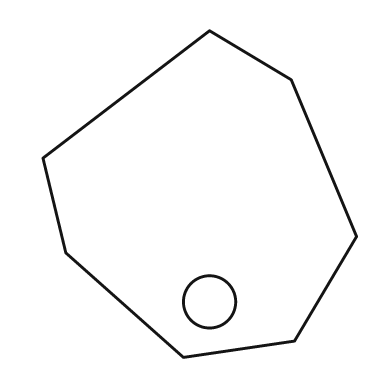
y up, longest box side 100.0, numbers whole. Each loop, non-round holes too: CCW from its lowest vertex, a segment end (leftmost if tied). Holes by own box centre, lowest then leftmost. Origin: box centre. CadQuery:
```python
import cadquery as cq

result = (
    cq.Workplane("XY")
    .moveTo(-5.0, -50.0)
    .lineTo(29.0, -45.0)
    .lineTo(48.0, -13.0)
    .lineTo(28.0, 35.0)
    .lineTo(3.0, 50.0)
    .lineTo(-48.0, 11.0)
    .lineTo(-41.0, -18.0)
    .close()
    .moveTo(3.0, -33.0)
    .circle(8.0)
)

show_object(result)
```